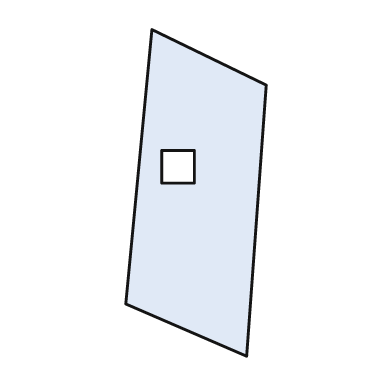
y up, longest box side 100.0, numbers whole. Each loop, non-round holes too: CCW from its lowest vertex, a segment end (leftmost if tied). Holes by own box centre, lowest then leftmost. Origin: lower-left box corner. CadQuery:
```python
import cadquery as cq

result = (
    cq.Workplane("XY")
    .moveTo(37.0, 0.0)
    .lineTo(43.0, 83.0)
    .lineTo(8.0, 100.0)
    .lineTo(0.0, 16.0)
    .close()
    .moveTo(11.0, 53.0)
    .lineTo(21.0, 53.0)
    .lineTo(21.0, 63.0)
    .lineTo(11.0, 63.0)
    .close()
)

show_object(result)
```